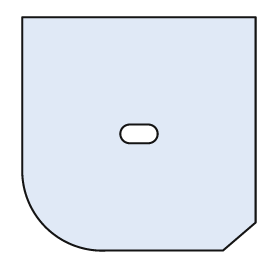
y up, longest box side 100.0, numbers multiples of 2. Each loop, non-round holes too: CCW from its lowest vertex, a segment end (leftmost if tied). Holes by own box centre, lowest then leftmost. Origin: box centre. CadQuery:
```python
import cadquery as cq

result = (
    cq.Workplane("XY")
    .moveTo(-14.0, -50.0)
    .lineTo(36.0, -50.0)
    .lineTo(50.0, -38.0)
    .lineTo(50.0, 50.0)
    .lineTo(-50.0, 50.0)
    .lineTo(-50.0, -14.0)
    .threePointArc((-40.0, -40.0), (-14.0, -50.0))
    .close()
    .moveTo(-4.0, -4.0)
    .lineTo(4.0, -4.0)
    .threePointArc((8.0, 0.0), (4.0, 4.0))
    .lineTo(-4.0, 4.0)
    .threePointArc((-8.0, 0.0), (-4.0, -4.0))
    .close()
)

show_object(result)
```